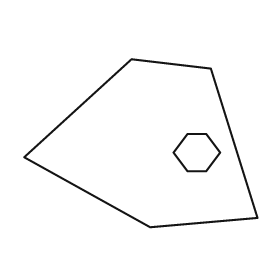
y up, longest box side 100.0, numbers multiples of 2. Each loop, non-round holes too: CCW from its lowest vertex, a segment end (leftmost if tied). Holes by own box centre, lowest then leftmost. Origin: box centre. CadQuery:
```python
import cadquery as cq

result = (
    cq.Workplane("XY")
    .moveTo(4.0, -36.0)
    .lineTo(50.0, -32.0)
    .lineTo(30.0, 32.0)
    .lineTo(-4.0, 36.0)
    .lineTo(-50.0, -6.0)
    .close()
    .moveTo(20.0, -12.0)
    .lineTo(28.0, -12.0)
    .lineTo(34.0, -4.0)
    .lineTo(28.0, 4.0)
    .lineTo(20.0, 4.0)
    .lineTo(14.0, -4.0)
    .close()
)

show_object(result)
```